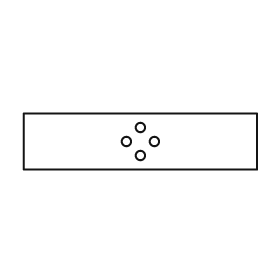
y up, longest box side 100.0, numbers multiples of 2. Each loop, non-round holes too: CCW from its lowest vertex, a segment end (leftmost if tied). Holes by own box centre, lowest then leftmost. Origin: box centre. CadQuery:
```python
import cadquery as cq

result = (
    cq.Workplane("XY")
    .moveTo(-50.0, -12.0)
    .lineTo(50.0, -12.0)
    .lineTo(50.0, 12.0)
    .lineTo(-50.0, 12.0)
    .close()
    .moveTo(0.0, -6.0)
    .circle(2.0)
    .moveTo(-6.0, 0.0)
    .circle(2.0)
    .moveTo(6.0, 0.0)
    .circle(2.0)
    .moveTo(0.0, 6.0)
    .circle(2.0)
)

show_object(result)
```